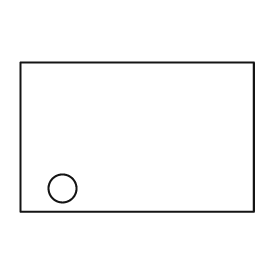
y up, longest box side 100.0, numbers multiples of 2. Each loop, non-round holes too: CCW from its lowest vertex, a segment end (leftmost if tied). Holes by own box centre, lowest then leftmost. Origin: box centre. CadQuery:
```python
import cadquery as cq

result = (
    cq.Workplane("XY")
    .moveTo(-50.0, -32.0)
    .lineTo(50.0, -32.0)
    .lineTo(50.0, 32.0)
    .lineTo(-50.0, 32.0)
    .close()
    .moveTo(-32.0, -22.0)
    .circle(6.0)
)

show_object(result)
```